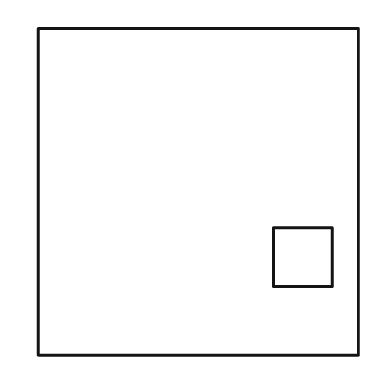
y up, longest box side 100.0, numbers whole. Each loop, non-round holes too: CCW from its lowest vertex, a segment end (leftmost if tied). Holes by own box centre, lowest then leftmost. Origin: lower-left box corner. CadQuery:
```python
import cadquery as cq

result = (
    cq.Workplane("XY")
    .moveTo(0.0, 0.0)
    .lineTo(98.0, 0.0)
    .lineTo(98.0, 100.0)
    .lineTo(0.0, 100.0)
    .close()
    .moveTo(72.0, 21.0)
    .lineTo(90.0, 21.0)
    .lineTo(90.0, 39.0)
    .lineTo(72.0, 39.0)
    .close()
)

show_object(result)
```